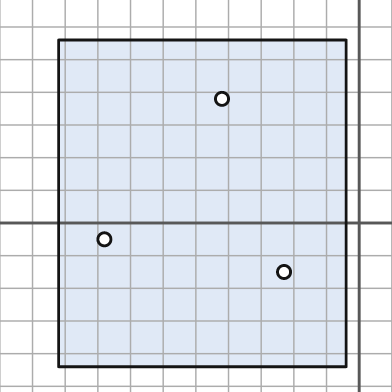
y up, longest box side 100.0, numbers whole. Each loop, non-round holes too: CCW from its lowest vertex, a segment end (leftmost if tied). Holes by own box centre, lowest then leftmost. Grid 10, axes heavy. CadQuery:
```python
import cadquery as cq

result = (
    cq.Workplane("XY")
    .moveTo(-92.0, -44.0)
    .lineTo(-4.0, -44.0)
    .lineTo(-4.0, 56.0)
    .lineTo(-92.0, 56.0)
    .close()
    .moveTo(-23.0, -15.0)
    .circle(2.0)
    .moveTo(-78.0, -5.0)
    .circle(2.0)
    .moveTo(-42.0, 38.0)
    .circle(2.0)
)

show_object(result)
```